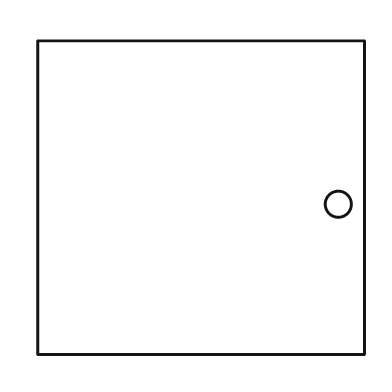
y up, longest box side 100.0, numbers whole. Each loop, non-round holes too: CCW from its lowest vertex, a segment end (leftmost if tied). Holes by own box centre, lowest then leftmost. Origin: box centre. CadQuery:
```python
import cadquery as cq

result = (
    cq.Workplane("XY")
    .moveTo(-50.0, -48.0)
    .lineTo(50.0, -48.0)
    .lineTo(50.0, 48.0)
    .lineTo(-50.0, 48.0)
    .close()
    .moveTo(42.0, -2.0)
    .circle(4.0)
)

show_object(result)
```